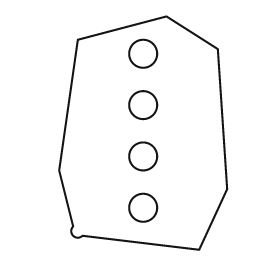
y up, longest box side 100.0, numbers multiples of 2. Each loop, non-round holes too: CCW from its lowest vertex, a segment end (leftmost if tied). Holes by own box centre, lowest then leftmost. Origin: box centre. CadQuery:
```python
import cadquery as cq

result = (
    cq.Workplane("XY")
    .moveTo(24.0, -50.0)
    .lineTo(36.0, -24.0)
    .lineTo(32.0, 36.0)
    .lineTo(10.0, 50.0)
    .lineTo(-28.0, 40.0)
    .lineTo(-36.0, -16.0)
    .lineTo(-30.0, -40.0)
    .threePointArc((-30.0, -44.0), (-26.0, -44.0))
    .close()
    .moveTo(0.0, -32.0)
    .circle(6.0)
    .moveTo(0.0, -10.0)
    .circle(6.0)
    .moveTo(0.0, 12.0)
    .circle(6.0)
    .moveTo(0.0, 34.0)
    .circle(6.0)
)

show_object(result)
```